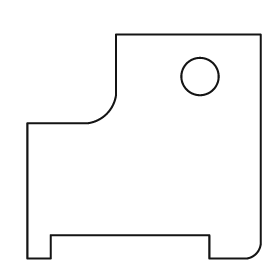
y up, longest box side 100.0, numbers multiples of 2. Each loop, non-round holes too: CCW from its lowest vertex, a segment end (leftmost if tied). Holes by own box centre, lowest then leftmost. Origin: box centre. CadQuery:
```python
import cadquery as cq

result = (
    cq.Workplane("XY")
    .moveTo(-50.0, -48.0)
    .lineTo(-40.0, -48.0)
    .lineTo(-40.0, -38.0)
    .lineTo(28.0, -38.0)
    .lineTo(28.0, -48.0)
    .lineTo(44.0, -48.0)
    .threePointArc((48.0, -46.0), (50.0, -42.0))
    .lineTo(50.0, 48.0)
    .lineTo(-12.0, 48.0)
    .lineTo(-12.0, 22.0)
    .threePointArc((-16.0, 14.0), (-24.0, 10.0))
    .lineTo(-50.0, 10.0)
    .close()
    .moveTo(24.0, 30.0)
    .circle(8.0)
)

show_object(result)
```